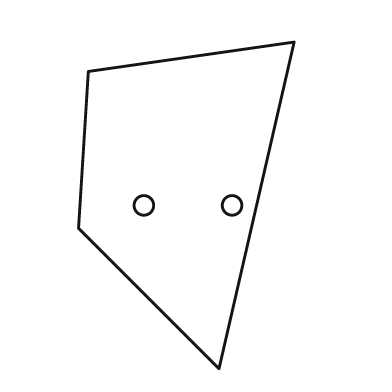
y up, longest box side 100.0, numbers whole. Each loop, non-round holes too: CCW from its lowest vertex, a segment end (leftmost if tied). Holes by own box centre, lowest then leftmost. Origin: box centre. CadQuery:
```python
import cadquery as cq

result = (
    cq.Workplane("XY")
    .moveTo(10.0, -50.0)
    .lineTo(33.0, 50.0)
    .lineTo(-30.0, 41.0)
    .lineTo(-33.0, -7.0)
    .close()
    .moveTo(-13.0, 0.0)
    .circle(3.0)
    .moveTo(14.0, 0.0)
    .circle(3.0)
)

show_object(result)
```